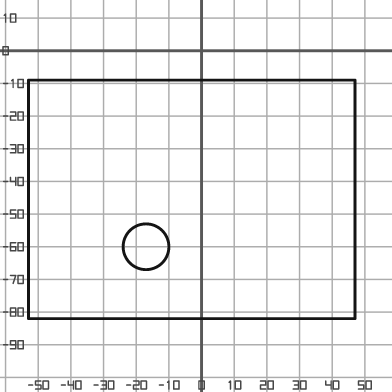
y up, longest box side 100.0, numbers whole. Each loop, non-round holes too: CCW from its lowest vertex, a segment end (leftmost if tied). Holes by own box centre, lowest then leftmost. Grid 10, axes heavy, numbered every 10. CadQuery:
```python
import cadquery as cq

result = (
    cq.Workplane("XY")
    .moveTo(-53.0, -82.0)
    .lineTo(47.0, -82.0)
    .lineTo(47.0, -9.0)
    .lineTo(-53.0, -9.0)
    .close()
    .moveTo(-17.0, -60.0)
    .circle(7.0)
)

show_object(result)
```